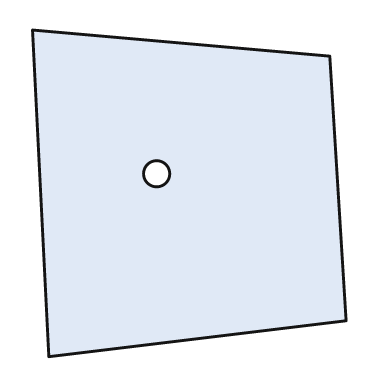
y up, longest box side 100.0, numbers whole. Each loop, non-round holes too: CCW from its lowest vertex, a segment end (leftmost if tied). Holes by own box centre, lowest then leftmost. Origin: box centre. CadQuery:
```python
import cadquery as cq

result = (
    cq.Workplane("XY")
    .moveTo(-43.0, -50.0)
    .lineTo(48.0, -39.0)
    .lineTo(43.0, 42.0)
    .lineTo(-48.0, 50.0)
    .close()
    .moveTo(-10.0, 6.0)
    .circle(4.0)
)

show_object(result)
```